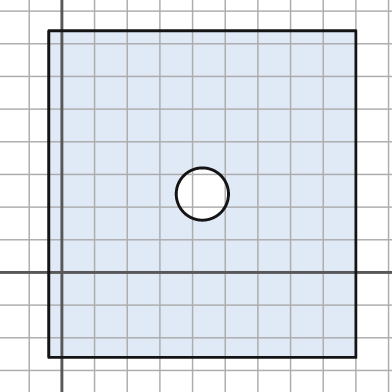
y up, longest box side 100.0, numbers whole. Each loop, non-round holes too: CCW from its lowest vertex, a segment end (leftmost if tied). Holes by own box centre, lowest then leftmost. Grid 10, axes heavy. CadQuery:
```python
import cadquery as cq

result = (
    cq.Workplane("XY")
    .moveTo(-4.0, -26.0)
    .lineTo(90.0, -26.0)
    .lineTo(90.0, 74.0)
    .lineTo(-4.0, 74.0)
    .close()
    .moveTo(43.0, 24.0)
    .circle(8.0)
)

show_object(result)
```